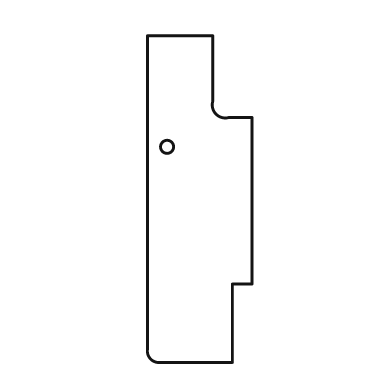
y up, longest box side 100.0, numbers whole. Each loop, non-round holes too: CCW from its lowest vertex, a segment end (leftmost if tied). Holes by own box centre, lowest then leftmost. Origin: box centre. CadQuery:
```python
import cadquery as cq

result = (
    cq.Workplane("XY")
    .moveTo(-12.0, -50.0)
    .lineTo(10.0, -50.0)
    .lineTo(10.0, -26.0)
    .lineTo(16.0, -26.0)
    .lineTo(16.0, 25.0)
    .lineTo(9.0, 25.0)
    .threePointArc((5.0, 26.0), (4.0, 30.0))
    .lineTo(4.0, 50.0)
    .lineTo(-16.0, 50.0)
    .lineTo(-16.0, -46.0)
    .threePointArc((-15.0, -49.0), (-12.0, -50.0))
    .close()
    .moveTo(-10.0, 16.0)
    .circle(2.0)
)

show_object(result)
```